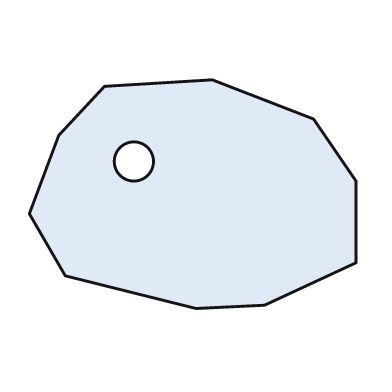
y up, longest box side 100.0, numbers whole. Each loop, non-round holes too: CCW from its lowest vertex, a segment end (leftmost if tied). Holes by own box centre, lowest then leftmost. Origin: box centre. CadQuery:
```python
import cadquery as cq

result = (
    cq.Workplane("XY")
    .moveTo(1.0, -35.0)
    .lineTo(22.0, -34.0)
    .lineTo(50.0, -21.0)
    .lineTo(50.0, 4.0)
    .lineTo(37.0, 23.0)
    .lineTo(6.0, 35.0)
    .lineTo(-27.0, 33.0)
    .lineTo(-41.0, 18.0)
    .lineTo(-50.0, -6.0)
    .lineTo(-39.0, -25.0)
    .close()
    .moveTo(-18.0, 10.0)
    .circle(6.0)
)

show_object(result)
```